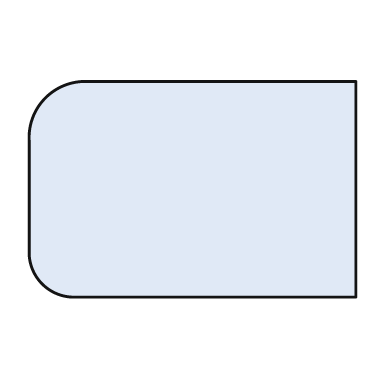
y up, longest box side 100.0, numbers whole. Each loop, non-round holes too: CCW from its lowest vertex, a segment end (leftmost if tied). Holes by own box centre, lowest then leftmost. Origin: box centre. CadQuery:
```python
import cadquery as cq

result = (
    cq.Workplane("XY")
    .moveTo(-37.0, -33.0)
    .lineTo(50.0, -33.0)
    .lineTo(50.0, 33.0)
    .lineTo(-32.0, 33.0)
    .threePointArc((-45.0, 28.0), (-50.0, 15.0))
    .lineTo(-50.0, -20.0)
    .threePointArc((-46.0, -29.0), (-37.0, -33.0))
    .close()
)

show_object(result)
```